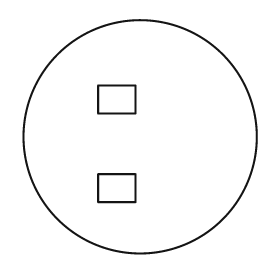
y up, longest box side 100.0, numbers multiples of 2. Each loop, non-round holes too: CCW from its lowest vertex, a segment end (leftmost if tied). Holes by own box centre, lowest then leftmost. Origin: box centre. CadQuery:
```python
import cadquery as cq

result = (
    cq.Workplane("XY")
    .moveTo(0.0, 0.0)
    .circle(50.0)
    .moveTo(-18.0, -28.0)
    .lineTo(-2.0, -28.0)
    .lineTo(-2.0, -16.0)
    .lineTo(-18.0, -16.0)
    .close()
    .moveTo(-18.0, 10.0)
    .lineTo(-2.0, 10.0)
    .lineTo(-2.0, 22.0)
    .lineTo(-18.0, 22.0)
    .close()
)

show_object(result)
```